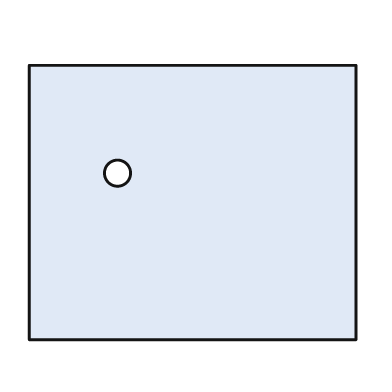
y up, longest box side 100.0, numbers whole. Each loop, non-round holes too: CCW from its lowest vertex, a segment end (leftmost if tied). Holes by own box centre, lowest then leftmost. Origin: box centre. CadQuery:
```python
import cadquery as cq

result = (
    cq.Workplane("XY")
    .moveTo(-50.0, -42.0)
    .lineTo(50.0, -42.0)
    .lineTo(50.0, 42.0)
    .lineTo(-50.0, 42.0)
    .close()
    .moveTo(-23.0, 9.0)
    .circle(4.0)
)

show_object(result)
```